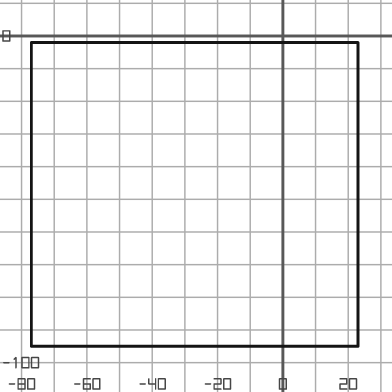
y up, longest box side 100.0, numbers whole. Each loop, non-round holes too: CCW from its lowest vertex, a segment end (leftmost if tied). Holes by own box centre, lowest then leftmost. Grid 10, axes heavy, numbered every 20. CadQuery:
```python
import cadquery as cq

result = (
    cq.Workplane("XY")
    .moveTo(-77.0, -95.0)
    .lineTo(23.0, -95.0)
    .lineTo(23.0, -2.0)
    .lineTo(-77.0, -2.0)
    .close()
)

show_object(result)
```